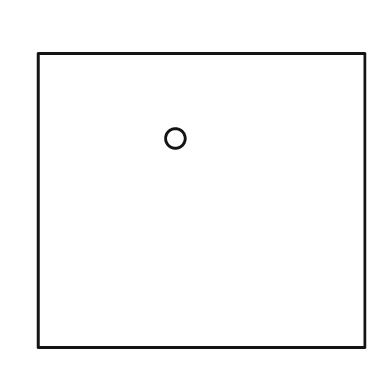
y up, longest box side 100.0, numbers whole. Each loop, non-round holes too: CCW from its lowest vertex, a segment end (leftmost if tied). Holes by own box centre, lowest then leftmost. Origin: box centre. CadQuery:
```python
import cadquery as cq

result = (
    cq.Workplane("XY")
    .moveTo(-50.0, -45.0)
    .lineTo(50.0, -45.0)
    .lineTo(50.0, 45.0)
    .lineTo(-50.0, 45.0)
    .close()
    .moveTo(-8.0, 19.0)
    .circle(3.0)
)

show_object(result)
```